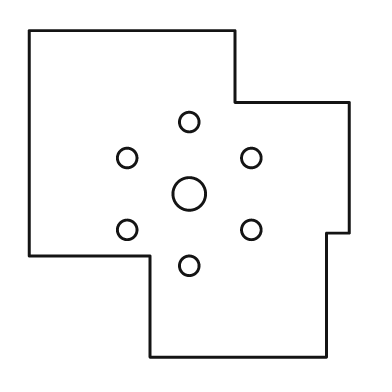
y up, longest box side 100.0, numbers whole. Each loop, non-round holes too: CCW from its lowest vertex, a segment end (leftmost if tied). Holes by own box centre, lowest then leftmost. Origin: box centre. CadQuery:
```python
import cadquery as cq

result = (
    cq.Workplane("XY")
    .moveTo(-12.0, -50.0)
    .lineTo(42.0, -50.0)
    .lineTo(42.0, -12.0)
    .lineTo(49.0, -12.0)
    .lineTo(49.0, 28.0)
    .lineTo(14.0, 28.0)
    .lineTo(14.0, 50.0)
    .lineTo(-49.0, 50.0)
    .lineTo(-49.0, -19.0)
    .lineTo(-12.0, -19.0)
    .close()
    .moveTo(0.0, -22.0)
    .circle(3.0)
    .moveTo(-19.0, -11.0)
    .circle(3.0)
    .moveTo(19.0, -11.0)
    .circle(3.0)
    .moveTo(0.0, 0.0)
    .circle(5.0)
    .moveTo(-19.0, 11.0)
    .circle(3.0)
    .moveTo(19.0, 11.0)
    .circle(3.0)
    .moveTo(0.0, 22.0)
    .circle(3.0)
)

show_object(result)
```